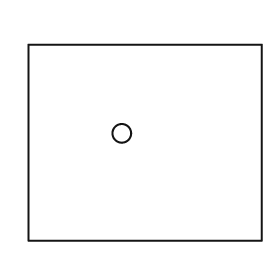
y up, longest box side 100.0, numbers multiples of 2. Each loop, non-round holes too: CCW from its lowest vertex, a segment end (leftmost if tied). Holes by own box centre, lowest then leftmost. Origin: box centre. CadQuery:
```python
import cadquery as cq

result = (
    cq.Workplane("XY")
    .moveTo(-50.0, -42.0)
    .lineTo(50.0, -42.0)
    .lineTo(50.0, 42.0)
    .lineTo(-50.0, 42.0)
    .close()
    .moveTo(-10.0, 4.0)
    .circle(4.0)
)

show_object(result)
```